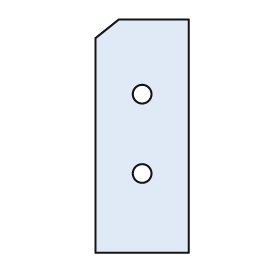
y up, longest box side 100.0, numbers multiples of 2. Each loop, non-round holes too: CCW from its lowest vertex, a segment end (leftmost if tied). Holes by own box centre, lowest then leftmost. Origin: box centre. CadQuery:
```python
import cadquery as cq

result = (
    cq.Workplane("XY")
    .moveTo(-20.0, -50.0)
    .lineTo(20.0, -50.0)
    .lineTo(20.0, 50.0)
    .lineTo(-10.0, 50.0)
    .lineTo(-20.0, 42.0)
    .close()
    .moveTo(0.0, -16.0)
    .circle(4.0)
    .moveTo(0.0, 18.0)
    .circle(4.0)
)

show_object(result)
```